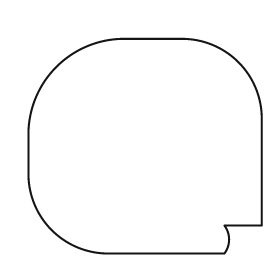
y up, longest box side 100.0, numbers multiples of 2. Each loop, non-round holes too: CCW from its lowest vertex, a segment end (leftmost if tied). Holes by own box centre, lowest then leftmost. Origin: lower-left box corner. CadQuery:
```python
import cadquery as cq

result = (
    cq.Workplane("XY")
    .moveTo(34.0, 0.0)
    .lineTo(84.0, 0.0)
    .threePointArc((86.0, 6.0), (84.0, 12.0))
    .lineTo(100.0, 12.0)
    .lineTo(100.0, 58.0)
    .threePointArc((90.0, 82.0), (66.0, 92.0))
    .lineTo(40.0, 92.0)
    .threePointArc((12.0, 80.0), (0.0, 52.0))
    .lineTo(0.0, 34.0)
    .threePointArc((10.0, 10.0), (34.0, 0.0))
    .close()
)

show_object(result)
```